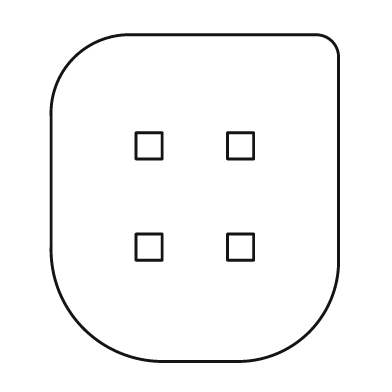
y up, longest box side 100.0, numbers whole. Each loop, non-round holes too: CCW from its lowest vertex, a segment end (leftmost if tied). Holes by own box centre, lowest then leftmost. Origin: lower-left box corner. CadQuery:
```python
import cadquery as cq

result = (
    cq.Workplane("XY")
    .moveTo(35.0, 0.0)
    .lineTo(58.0, 0.0)
    .threePointArc((79.0, 9.0), (88.0, 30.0))
    .lineTo(88.0, 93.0)
    .threePointArc((86.0, 98.0), (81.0, 100.0))
    .lineTo(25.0, 100.0)
    .threePointArc((7.0, 93.0), (0.0, 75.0))
    .lineTo(0.0, 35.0)
    .threePointArc((10.0, 10.0), (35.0, 0.0))
    .close()
    .moveTo(26.0, 31.0)
    .lineTo(34.0, 31.0)
    .lineTo(34.0, 39.0)
    .lineTo(26.0, 39.0)
    .close()
    .moveTo(54.0, 31.0)
    .lineTo(62.0, 31.0)
    .lineTo(62.0, 39.0)
    .lineTo(54.0, 39.0)
    .close()
    .moveTo(26.0, 62.0)
    .lineTo(34.0, 62.0)
    .lineTo(34.0, 70.0)
    .lineTo(26.0, 70.0)
    .close()
    .moveTo(54.0, 62.0)
    .lineTo(62.0, 62.0)
    .lineTo(62.0, 70.0)
    .lineTo(54.0, 70.0)
    .close()
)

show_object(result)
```